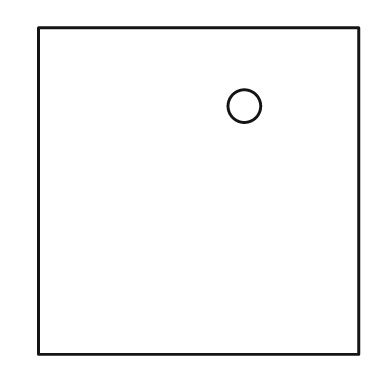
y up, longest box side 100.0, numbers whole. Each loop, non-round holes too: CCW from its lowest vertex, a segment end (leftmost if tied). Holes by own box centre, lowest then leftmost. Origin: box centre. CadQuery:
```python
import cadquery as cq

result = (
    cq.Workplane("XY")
    .moveTo(-49.0, -50.0)
    .lineTo(49.0, -50.0)
    .lineTo(49.0, 50.0)
    .lineTo(-49.0, 50.0)
    .close()
    .moveTo(14.0, 26.0)
    .circle(5.0)
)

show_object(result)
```